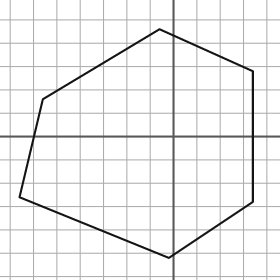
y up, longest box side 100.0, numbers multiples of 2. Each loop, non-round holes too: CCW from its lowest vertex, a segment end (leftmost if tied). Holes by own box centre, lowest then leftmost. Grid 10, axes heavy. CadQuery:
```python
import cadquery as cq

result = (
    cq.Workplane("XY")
    .moveTo(-2.0, -52.0)
    .lineTo(34.0, -28.0)
    .lineTo(34.0, 28.0)
    .lineTo(-6.0, 46.0)
    .lineTo(-56.0, 16.0)
    .lineTo(-66.0, -26.0)
    .close()
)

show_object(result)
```